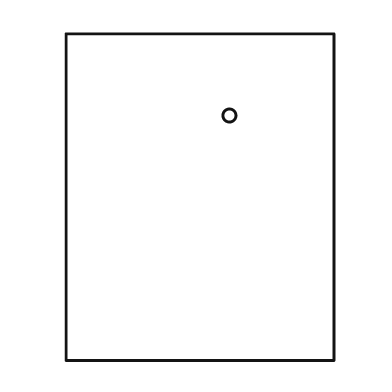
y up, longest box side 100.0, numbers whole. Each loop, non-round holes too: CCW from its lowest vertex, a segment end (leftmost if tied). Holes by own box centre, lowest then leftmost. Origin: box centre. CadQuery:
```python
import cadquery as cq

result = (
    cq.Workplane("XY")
    .moveTo(-41.0, -50.0)
    .lineTo(41.0, -50.0)
    .lineTo(41.0, 50.0)
    .lineTo(-41.0, 50.0)
    .close()
    .moveTo(9.0, 25.0)
    .circle(2.0)
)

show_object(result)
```